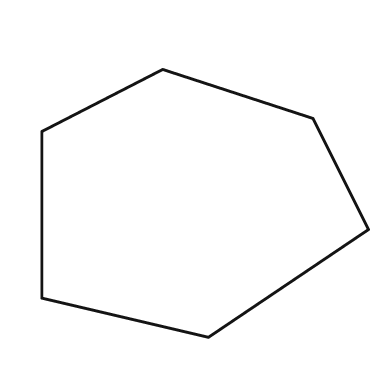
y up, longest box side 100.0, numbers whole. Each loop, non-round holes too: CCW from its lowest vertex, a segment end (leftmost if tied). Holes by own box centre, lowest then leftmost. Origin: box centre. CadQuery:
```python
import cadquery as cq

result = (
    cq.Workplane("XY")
    .moveTo(1.0, -41.0)
    .lineTo(50.0, -8.0)
    .lineTo(33.0, 26.0)
    .lineTo(-13.0, 41.0)
    .lineTo(-50.0, 22.0)
    .lineTo(-50.0, -29.0)
    .close()
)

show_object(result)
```